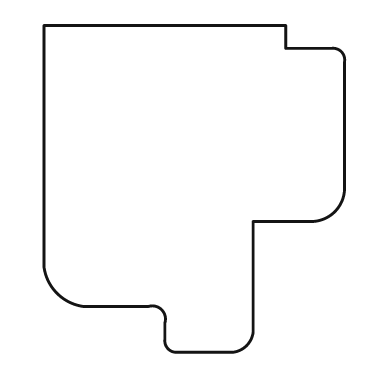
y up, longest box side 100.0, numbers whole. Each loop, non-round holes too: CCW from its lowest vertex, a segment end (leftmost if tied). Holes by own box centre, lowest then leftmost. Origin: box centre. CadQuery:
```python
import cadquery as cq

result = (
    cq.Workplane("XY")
    .moveTo(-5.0, -50.0)
    .lineTo(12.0, -50.0)
    .threePointArc((16.0, -48.0), (18.0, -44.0))
    .lineTo(18.0, -10.0)
    .lineTo(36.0, -10.0)
    .threePointArc((43.0, -7.0), (46.0, 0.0))
    .lineTo(46.0, 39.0)
    .threePointArc((45.0, 42.0), (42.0, 43.0))
    .lineTo(28.0, 43.0)
    .lineTo(28.0, 50.0)
    .lineTo(-46.0, 50.0)
    .lineTo(-46.0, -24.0)
    .threePointArc((-42.0, -32.0), (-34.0, -36.0))
    .lineTo(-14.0, -36.0)
    .threePointArc((-10.0, -37.0), (-9.0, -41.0))
    .lineTo(-9.0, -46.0)
    .threePointArc((-8.0, -49.0), (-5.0, -50.0))
    .close()
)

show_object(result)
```